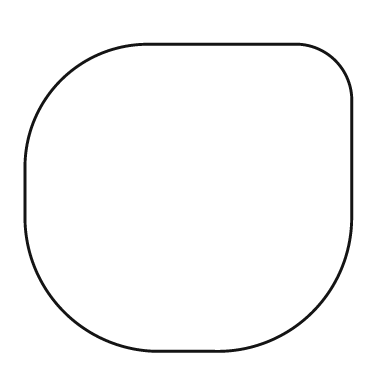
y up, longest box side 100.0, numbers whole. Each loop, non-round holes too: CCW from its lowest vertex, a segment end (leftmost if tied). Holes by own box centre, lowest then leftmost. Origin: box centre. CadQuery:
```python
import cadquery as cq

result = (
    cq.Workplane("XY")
    .moveTo(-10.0, -47.0)
    .lineTo(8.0, -47.0)
    .threePointArc((38.0, -35.0), (50.0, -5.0))
    .lineTo(50.0, 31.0)
    .threePointArc((45.0, 42.0), (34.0, 47.0))
    .lineTo(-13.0, 47.0)
    .threePointArc((-39.0, 36.0), (-50.0, 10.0))
    .lineTo(-50.0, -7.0)
    .threePointArc((-38.0, -35.0), (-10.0, -47.0))
    .close()
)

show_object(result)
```